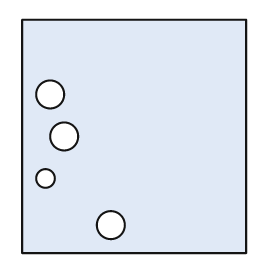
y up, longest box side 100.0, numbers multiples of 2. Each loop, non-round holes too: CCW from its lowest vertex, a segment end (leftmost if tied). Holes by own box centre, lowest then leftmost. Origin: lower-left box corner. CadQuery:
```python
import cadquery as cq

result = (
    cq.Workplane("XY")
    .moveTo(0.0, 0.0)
    .lineTo(96.0, 0.0)
    .lineTo(96.0, 100.0)
    .lineTo(0.0, 100.0)
    .close()
    .moveTo(38.0, 12.0)
    .circle(6.0)
    .moveTo(10.0, 32.0)
    .circle(4.0)
    .moveTo(18.0, 50.0)
    .circle(6.0)
    .moveTo(12.0, 68.0)
    .circle(6.0)
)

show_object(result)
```